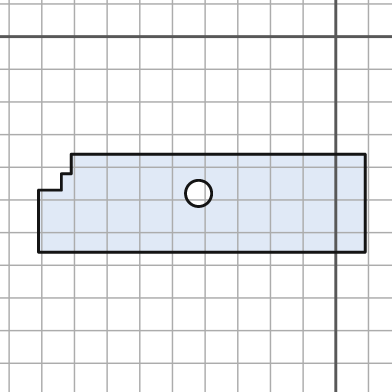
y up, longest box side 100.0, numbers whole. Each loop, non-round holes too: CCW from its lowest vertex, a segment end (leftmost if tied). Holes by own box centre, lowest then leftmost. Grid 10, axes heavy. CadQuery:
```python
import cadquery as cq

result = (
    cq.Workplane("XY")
    .moveTo(-91.0, -66.0)
    .lineTo(9.0, -66.0)
    .lineTo(9.0, -36.0)
    .lineTo(-81.0, -36.0)
    .lineTo(-81.0, -42.0)
    .lineTo(-84.0, -42.0)
    .lineTo(-84.0, -47.0)
    .lineTo(-91.0, -47.0)
    .close()
    .moveTo(-42.0, -48.0)
    .circle(4.0)
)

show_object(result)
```